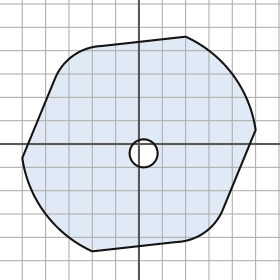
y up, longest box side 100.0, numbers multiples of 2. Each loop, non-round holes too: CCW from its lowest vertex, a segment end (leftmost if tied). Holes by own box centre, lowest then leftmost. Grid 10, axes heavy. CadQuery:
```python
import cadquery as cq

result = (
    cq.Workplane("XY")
    .moveTo(-20.0, -46.0)
    .lineTo(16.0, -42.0)
    .threePointArc((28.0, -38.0), (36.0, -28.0))
    .lineTo(50.0, 6.0)
    .threePointArc((40.0, 30.0), (20.0, 46.0))
    .lineTo(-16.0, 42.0)
    .threePointArc((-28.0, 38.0), (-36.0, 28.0))
    .lineTo(-50.0, -6.0)
    .threePointArc((-40.0, -30.0), (-20.0, -46.0))
    .close()
    .moveTo(2.0, -4.0)
    .circle(6.0)
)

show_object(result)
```